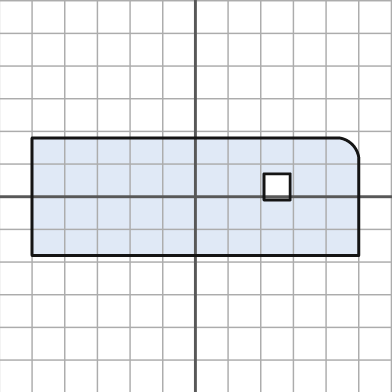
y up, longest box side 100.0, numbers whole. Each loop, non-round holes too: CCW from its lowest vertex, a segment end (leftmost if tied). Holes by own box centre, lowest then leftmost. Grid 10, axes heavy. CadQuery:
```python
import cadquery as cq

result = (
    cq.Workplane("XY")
    .moveTo(-50.0, -18.0)
    .lineTo(50.0, -18.0)
    .lineTo(50.0, 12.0)
    .threePointArc((48.0, 16.0), (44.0, 18.0))
    .lineTo(-50.0, 18.0)
    .close()
    .moveTo(21.0, -1.0)
    .lineTo(29.0, -1.0)
    .lineTo(29.0, 7.0)
    .lineTo(21.0, 7.0)
    .close()
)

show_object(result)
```